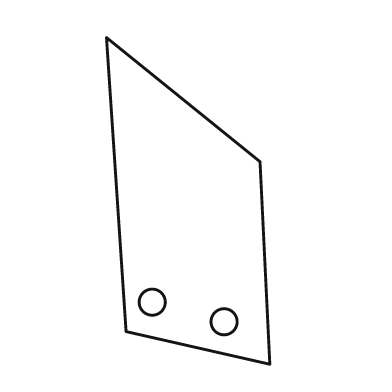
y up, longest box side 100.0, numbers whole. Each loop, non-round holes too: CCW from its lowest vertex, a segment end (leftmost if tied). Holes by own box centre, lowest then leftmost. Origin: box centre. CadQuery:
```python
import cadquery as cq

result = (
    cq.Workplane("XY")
    .moveTo(25.0, -50.0)
    .lineTo(22.0, 12.0)
    .lineTo(-25.0, 50.0)
    .lineTo(-19.0, -40.0)
    .close()
    .moveTo(11.0, -37.0)
    .circle(4.0)
    .moveTo(-11.0, -31.0)
    .circle(4.0)
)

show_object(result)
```